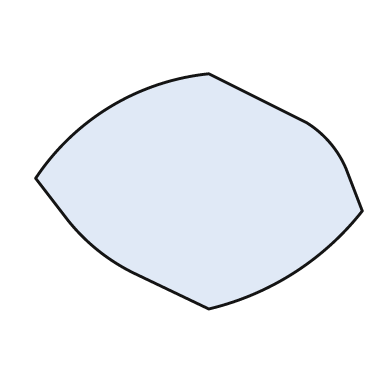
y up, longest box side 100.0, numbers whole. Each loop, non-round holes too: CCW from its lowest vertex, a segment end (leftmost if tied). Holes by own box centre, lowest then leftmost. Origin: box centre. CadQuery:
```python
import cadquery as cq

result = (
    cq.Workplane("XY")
    .moveTo(3.0, -36.0)
    .threePointArc((29.0, -25.0), (50.0, -6.0))
    .lineTo(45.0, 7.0)
    .threePointArc((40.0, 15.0), (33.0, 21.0))
    .lineTo(3.0, 36.0)
    .threePointArc((-27.0, 26.0), (-50.0, 4.0))
    .lineTo(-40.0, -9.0)
    .threePointArc((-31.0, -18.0), (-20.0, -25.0))
    .close()
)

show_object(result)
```